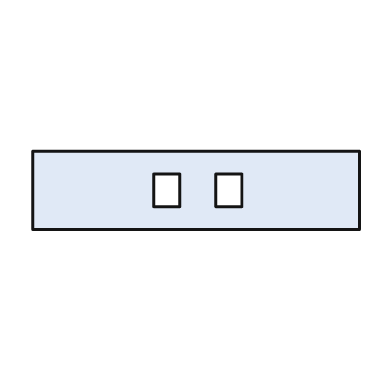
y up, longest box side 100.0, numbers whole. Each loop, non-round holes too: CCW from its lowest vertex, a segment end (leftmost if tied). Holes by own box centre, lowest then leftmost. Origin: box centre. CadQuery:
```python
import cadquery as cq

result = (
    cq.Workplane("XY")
    .moveTo(-50.0, -12.0)
    .lineTo(50.0, -12.0)
    .lineTo(50.0, 12.0)
    .lineTo(-50.0, 12.0)
    .close()
    .moveTo(-13.0, -5.0)
    .lineTo(-5.0, -5.0)
    .lineTo(-5.0, 5.0)
    .lineTo(-13.0, 5.0)
    .close()
    .moveTo(6.0, -5.0)
    .lineTo(14.0, -5.0)
    .lineTo(14.0, 5.0)
    .lineTo(6.0, 5.0)
    .close()
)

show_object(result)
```